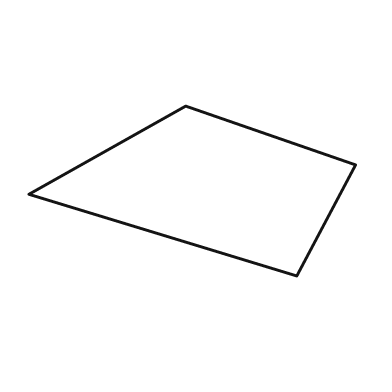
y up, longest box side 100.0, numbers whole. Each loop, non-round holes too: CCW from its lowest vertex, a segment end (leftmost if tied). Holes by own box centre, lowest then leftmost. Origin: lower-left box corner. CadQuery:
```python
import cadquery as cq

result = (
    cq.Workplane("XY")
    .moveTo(82.0, 0.0)
    .lineTo(100.0, 34.0)
    .lineTo(48.0, 52.0)
    .lineTo(0.0, 25.0)
    .close()
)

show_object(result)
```